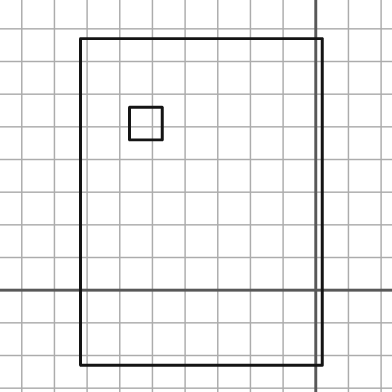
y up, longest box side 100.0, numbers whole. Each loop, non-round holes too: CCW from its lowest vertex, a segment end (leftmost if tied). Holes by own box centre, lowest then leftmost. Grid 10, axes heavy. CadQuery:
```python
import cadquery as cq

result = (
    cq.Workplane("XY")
    .moveTo(-72.0, -23.0)
    .lineTo(2.0, -23.0)
    .lineTo(2.0, 77.0)
    .lineTo(-72.0, 77.0)
    .close()
    .moveTo(-57.0, 46.0)
    .lineTo(-47.0, 46.0)
    .lineTo(-47.0, 56.0)
    .lineTo(-57.0, 56.0)
    .close()
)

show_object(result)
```